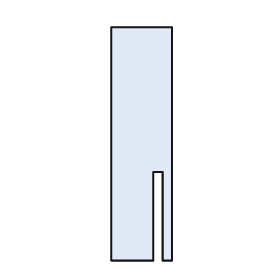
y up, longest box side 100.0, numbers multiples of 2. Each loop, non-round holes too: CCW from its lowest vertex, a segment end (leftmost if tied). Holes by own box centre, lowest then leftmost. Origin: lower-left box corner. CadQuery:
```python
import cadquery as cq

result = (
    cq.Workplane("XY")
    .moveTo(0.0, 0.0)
    .lineTo(18.0, 0.0)
    .lineTo(18.0, 38.0)
    .lineTo(22.0, 38.0)
    .lineTo(22.0, 0.0)
    .lineTo(26.0, 0.0)
    .lineTo(26.0, 100.0)
    .lineTo(0.0, 100.0)
    .close()
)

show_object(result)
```